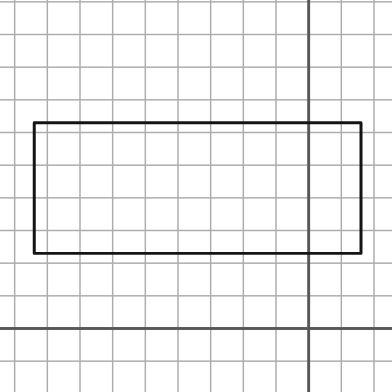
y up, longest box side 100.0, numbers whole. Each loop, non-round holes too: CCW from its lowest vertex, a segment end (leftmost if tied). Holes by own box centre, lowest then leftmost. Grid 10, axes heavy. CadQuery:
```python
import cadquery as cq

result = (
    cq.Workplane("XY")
    .moveTo(-84.0, 23.0)
    .lineTo(16.0, 23.0)
    .lineTo(16.0, 63.0)
    .lineTo(-84.0, 63.0)
    .close()
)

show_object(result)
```